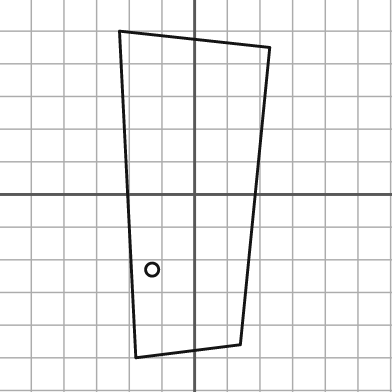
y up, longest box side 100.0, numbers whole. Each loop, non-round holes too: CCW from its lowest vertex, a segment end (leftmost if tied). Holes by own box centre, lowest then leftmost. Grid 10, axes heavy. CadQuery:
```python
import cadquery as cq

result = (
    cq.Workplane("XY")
    .moveTo(-18.0, -50.0)
    .lineTo(14.0, -46.0)
    .lineTo(23.0, 45.0)
    .lineTo(-23.0, 50.0)
    .close()
    .moveTo(-13.0, -23.0)
    .circle(2.0)
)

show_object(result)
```